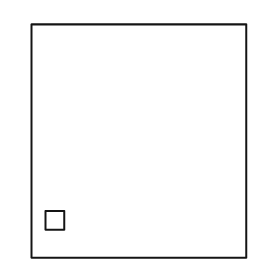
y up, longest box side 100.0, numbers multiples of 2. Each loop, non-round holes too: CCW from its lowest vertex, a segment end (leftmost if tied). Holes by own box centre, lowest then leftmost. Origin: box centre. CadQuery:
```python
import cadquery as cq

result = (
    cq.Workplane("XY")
    .moveTo(-46.0, -50.0)
    .lineTo(46.0, -50.0)
    .lineTo(46.0, 50.0)
    .lineTo(-46.0, 50.0)
    .close()
    .moveTo(-40.0, -38.0)
    .lineTo(-32.0, -38.0)
    .lineTo(-32.0, -30.0)
    .lineTo(-40.0, -30.0)
    .close()
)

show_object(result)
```